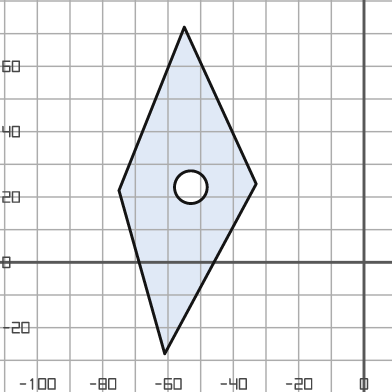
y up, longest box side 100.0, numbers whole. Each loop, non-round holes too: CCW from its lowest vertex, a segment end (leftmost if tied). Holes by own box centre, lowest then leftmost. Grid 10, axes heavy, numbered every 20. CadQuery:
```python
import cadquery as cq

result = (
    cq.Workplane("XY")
    .moveTo(-61.0, -28.0)
    .lineTo(-33.0, 24.0)
    .lineTo(-55.0, 72.0)
    .lineTo(-75.0, 22.0)
    .close()
    .moveTo(-53.0, 23.0)
    .circle(5.0)
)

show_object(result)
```